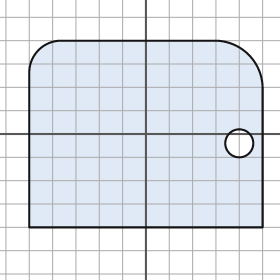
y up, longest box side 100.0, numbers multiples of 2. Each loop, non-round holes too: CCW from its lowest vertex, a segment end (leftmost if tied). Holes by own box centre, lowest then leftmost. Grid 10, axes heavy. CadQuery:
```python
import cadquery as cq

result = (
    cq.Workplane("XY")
    .moveTo(-50.0, -40.0)
    .lineTo(50.0, -40.0)
    .lineTo(50.0, 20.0)
    .threePointArc((44.0, 34.0), (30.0, 40.0))
    .lineTo(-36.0, 40.0)
    .threePointArc((-46.0, 36.0), (-50.0, 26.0))
    .close()
    .moveTo(40.0, -4.0)
    .circle(6.0)
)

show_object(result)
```